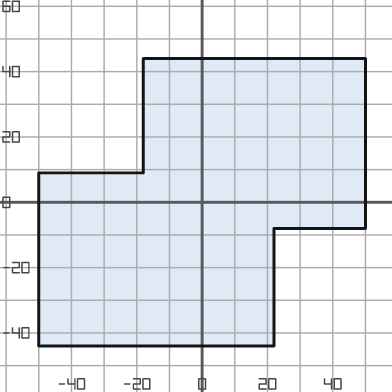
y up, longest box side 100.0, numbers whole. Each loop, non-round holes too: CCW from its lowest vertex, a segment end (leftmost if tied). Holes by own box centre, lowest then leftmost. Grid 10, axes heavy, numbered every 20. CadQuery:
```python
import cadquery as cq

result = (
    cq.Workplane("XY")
    .moveTo(-50.0, -44.0)
    .lineTo(22.0, -44.0)
    .lineTo(22.0, -8.0)
    .lineTo(50.0, -8.0)
    .lineTo(50.0, 44.0)
    .lineTo(-18.0, 44.0)
    .lineTo(-18.0, 9.0)
    .lineTo(-50.0, 9.0)
    .close()
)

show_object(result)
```